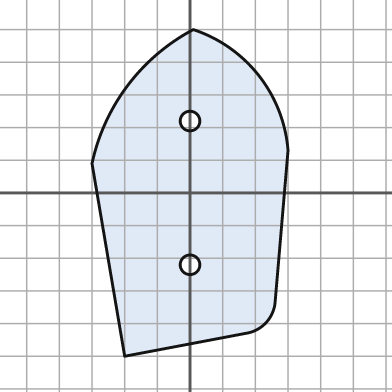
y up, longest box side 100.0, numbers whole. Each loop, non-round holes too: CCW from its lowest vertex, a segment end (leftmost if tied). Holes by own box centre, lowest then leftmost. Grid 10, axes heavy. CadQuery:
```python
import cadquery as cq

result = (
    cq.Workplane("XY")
    .moveTo(-20.0, -50.0)
    .lineTo(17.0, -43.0)
    .threePointArc((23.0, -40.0), (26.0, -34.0))
    .lineTo(30.0, 13.0)
    .threePointArc((21.0, 36.0), (1.0, 50.0))
    .threePointArc((-19.0, 33.0), (-30.0, 9.0))
    .close()
    .moveTo(0.0, -22.0)
    .circle(3.0)
    .moveTo(0.0, 22.0)
    .circle(3.0)
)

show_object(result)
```